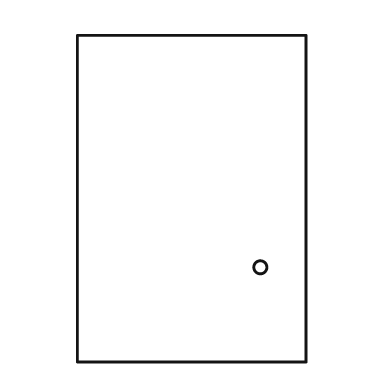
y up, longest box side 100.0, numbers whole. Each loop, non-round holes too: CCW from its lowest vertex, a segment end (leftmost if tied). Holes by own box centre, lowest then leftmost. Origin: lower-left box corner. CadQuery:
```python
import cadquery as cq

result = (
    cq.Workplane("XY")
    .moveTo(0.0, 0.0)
    .lineTo(70.0, 0.0)
    .lineTo(70.0, 100.0)
    .lineTo(0.0, 100.0)
    .close()
    .moveTo(56.0, 29.0)
    .circle(2.0)
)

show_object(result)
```